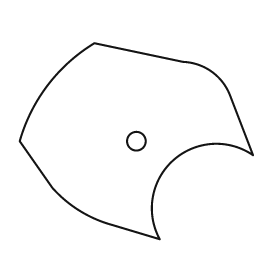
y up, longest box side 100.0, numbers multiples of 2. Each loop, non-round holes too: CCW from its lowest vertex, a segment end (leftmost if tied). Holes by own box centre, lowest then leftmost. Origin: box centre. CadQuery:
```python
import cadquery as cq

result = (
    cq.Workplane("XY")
    .moveTo(10.0, -42.0)
    .threePointArc((16.0, -8.0), (50.0, -6.0))
    .lineTo(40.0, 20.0)
    .threePointArc((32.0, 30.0), (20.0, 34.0))
    .lineTo(-18.0, 42.0)
    .threePointArc((-38.0, 24.0), (-50.0, 0.0))
    .lineTo(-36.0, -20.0)
    .threePointArc((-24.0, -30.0), (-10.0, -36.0))
    .close()
    .moveTo(0.0, 0.0)
    .circle(4.0)
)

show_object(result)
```